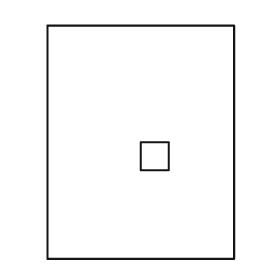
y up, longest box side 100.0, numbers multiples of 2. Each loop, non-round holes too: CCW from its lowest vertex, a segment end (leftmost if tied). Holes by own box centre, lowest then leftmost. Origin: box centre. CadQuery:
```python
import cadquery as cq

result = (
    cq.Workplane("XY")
    .moveTo(-40.0, -50.0)
    .lineTo(40.0, -50.0)
    .lineTo(40.0, 50.0)
    .lineTo(-40.0, 50.0)
    .close()
    .moveTo(0.0, -12.0)
    .lineTo(12.0, -12.0)
    .lineTo(12.0, 0.0)
    .lineTo(0.0, 0.0)
    .close()
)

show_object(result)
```